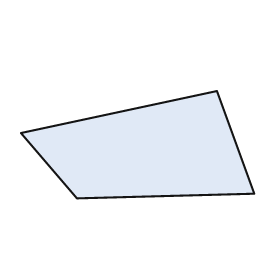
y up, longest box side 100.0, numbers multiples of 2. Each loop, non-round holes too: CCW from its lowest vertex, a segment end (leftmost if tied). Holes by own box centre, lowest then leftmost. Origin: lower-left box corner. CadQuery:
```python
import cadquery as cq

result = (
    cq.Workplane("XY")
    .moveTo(24.0, 0.0)
    .lineTo(100.0, 2.0)
    .lineTo(84.0, 46.0)
    .lineTo(0.0, 28.0)
    .close()
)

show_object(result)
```